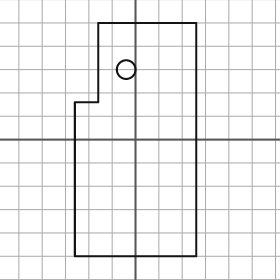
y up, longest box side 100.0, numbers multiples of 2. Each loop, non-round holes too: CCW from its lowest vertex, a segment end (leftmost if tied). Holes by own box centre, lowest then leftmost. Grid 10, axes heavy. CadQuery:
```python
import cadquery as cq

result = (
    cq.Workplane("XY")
    .moveTo(-26.0, -50.0)
    .lineTo(26.0, -50.0)
    .lineTo(26.0, 50.0)
    .lineTo(-16.0, 50.0)
    .lineTo(-16.0, 16.0)
    .lineTo(-26.0, 16.0)
    .close()
    .moveTo(-4.0, 30.0)
    .circle(4.0)
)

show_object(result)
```